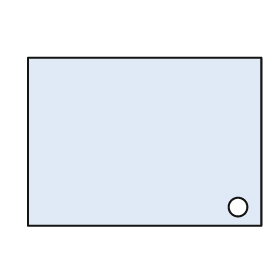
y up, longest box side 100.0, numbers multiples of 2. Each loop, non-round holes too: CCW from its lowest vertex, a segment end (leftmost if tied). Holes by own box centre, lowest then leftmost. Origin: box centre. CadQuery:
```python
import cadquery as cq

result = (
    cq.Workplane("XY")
    .moveTo(-50.0, -36.0)
    .lineTo(50.0, -36.0)
    .lineTo(50.0, 36.0)
    .lineTo(-50.0, 36.0)
    .close()
    .moveTo(40.0, -28.0)
    .circle(4.0)
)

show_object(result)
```